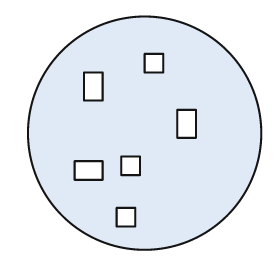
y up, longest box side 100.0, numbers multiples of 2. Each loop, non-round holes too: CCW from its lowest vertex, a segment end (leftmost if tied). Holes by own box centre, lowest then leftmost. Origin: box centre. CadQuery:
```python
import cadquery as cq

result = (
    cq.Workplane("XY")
    .moveTo(0.0, 0.0)
    .circle(50.0)
    .moveTo(-12.0, -40.0)
    .lineTo(-4.0, -40.0)
    .lineTo(-4.0, -32.0)
    .lineTo(-12.0, -32.0)
    .close()
    .moveTo(-30.0, -20.0)
    .lineTo(-18.0, -20.0)
    .lineTo(-18.0, -12.0)
    .lineTo(-30.0, -12.0)
    .close()
    .moveTo(-10.0, -18.0)
    .lineTo(-2.0, -18.0)
    .lineTo(-2.0, -10.0)
    .lineTo(-10.0, -10.0)
    .close()
    .moveTo(14.0, -2.0)
    .lineTo(22.0, -2.0)
    .lineTo(22.0, 10.0)
    .lineTo(14.0, 10.0)
    .close()
    .moveTo(-26.0, 14.0)
    .lineTo(-18.0, 14.0)
    .lineTo(-18.0, 26.0)
    .lineTo(-26.0, 26.0)
    .close()
    .moveTo(0.0, 26.0)
    .lineTo(8.0, 26.0)
    .lineTo(8.0, 34.0)
    .lineTo(0.0, 34.0)
    .close()
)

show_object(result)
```